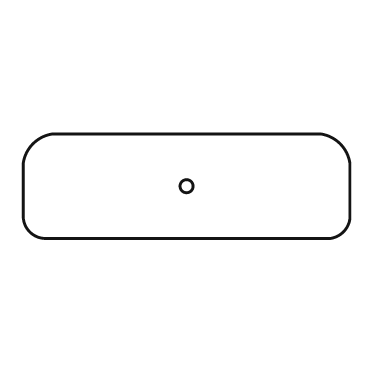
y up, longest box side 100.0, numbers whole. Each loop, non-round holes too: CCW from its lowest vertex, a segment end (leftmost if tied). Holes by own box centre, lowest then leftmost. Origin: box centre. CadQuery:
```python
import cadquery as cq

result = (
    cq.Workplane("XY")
    .moveTo(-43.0, -16.0)
    .lineTo(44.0, -16.0)
    .threePointArc((48.0, -14.0), (50.0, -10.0))
    .lineTo(50.0, 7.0)
    .threePointArc((47.0, 13.0), (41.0, 16.0))
    .lineTo(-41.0, 16.0)
    .threePointArc((-47.0, 13.0), (-50.0, 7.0))
    .lineTo(-50.0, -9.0)
    .threePointArc((-48.0, -14.0), (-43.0, -16.0))
    .close()
    .moveTo(0.0, 0.0)
    .circle(2.0)
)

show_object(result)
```